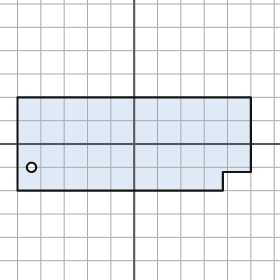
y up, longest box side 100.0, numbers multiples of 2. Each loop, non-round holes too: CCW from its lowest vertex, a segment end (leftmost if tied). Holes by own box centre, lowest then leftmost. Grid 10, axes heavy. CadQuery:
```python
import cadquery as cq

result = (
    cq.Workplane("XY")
    .moveTo(-50.0, -20.0)
    .lineTo(38.0, -20.0)
    .lineTo(38.0, -12.0)
    .lineTo(50.0, -12.0)
    .lineTo(50.0, 20.0)
    .lineTo(-50.0, 20.0)
    .close()
    .moveTo(-44.0, -10.0)
    .circle(2.0)
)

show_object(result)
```